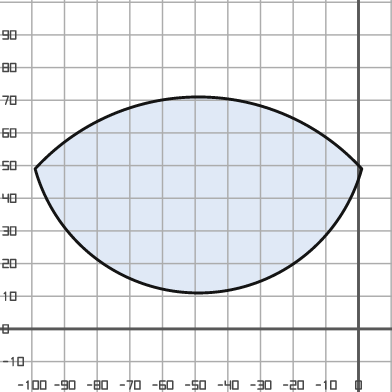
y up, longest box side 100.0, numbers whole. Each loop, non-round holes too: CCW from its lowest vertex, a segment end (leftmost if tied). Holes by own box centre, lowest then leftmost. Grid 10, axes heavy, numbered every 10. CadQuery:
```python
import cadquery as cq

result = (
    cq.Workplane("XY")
    .moveTo(-99.0, 49.0)
    .threePointArc((-49.0, 11.0), (1.0, 49.0))
    .threePointArc((-49.0, 71.0), (-99.0, 49.0))
    .close()
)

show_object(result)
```